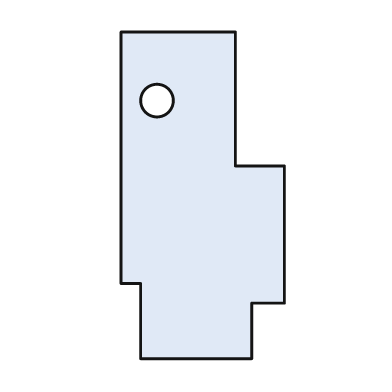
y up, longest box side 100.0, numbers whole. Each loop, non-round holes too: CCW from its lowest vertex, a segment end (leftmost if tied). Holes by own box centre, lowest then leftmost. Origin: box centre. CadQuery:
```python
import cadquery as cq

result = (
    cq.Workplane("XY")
    .moveTo(-19.0, -50.0)
    .lineTo(15.0, -50.0)
    .lineTo(15.0, -33.0)
    .lineTo(25.0, -33.0)
    .lineTo(25.0, 9.0)
    .lineTo(10.0, 9.0)
    .lineTo(10.0, 50.0)
    .lineTo(-25.0, 50.0)
    .lineTo(-25.0, -27.0)
    .lineTo(-19.0, -27.0)
    .close()
    .moveTo(-14.0, 29.0)
    .circle(5.0)
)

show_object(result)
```